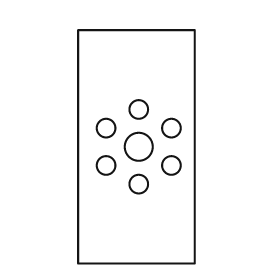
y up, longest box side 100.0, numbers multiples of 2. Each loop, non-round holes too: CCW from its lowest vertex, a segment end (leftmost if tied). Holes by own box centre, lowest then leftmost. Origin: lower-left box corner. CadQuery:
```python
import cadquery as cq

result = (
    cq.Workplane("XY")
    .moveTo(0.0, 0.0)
    .lineTo(50.0, 0.0)
    .lineTo(50.0, 100.0)
    .lineTo(0.0, 100.0)
    .close()
    .moveTo(26.0, 34.0)
    .circle(4.0)
    .moveTo(12.0, 42.0)
    .circle(4.0)
    .moveTo(40.0, 42.0)
    .circle(4.0)
    .moveTo(26.0, 50.0)
    .circle(6.0)
    .moveTo(12.0, 58.0)
    .circle(4.0)
    .moveTo(40.0, 58.0)
    .circle(4.0)
    .moveTo(26.0, 66.0)
    .circle(4.0)
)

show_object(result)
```